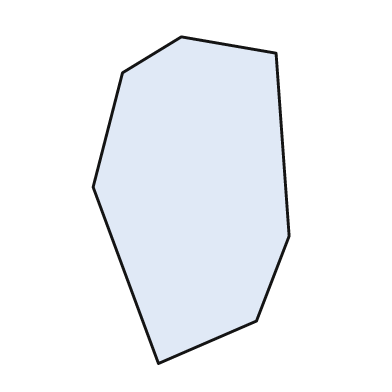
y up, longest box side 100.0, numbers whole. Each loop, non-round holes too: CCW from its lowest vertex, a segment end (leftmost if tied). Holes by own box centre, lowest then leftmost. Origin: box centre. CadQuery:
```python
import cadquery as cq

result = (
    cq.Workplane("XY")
    .moveTo(-10.0, -50.0)
    .lineTo(20.0, -37.0)
    .lineTo(30.0, -11.0)
    .lineTo(26.0, 45.0)
    .lineTo(-3.0, 50.0)
    .lineTo(-21.0, 39.0)
    .lineTo(-30.0, 4.0)
    .close()
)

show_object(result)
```